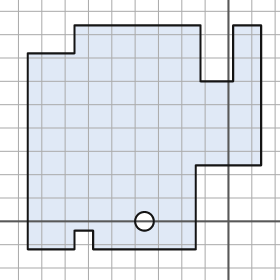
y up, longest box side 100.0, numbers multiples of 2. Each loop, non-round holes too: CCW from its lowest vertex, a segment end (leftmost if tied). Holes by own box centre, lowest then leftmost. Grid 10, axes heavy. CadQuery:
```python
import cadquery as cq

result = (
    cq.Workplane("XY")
    .moveTo(-86.0, -12.0)
    .lineTo(-66.0, -12.0)
    .lineTo(-66.0, -4.0)
    .lineTo(-58.0, -4.0)
    .lineTo(-58.0, -12.0)
    .lineTo(-14.0, -12.0)
    .lineTo(-14.0, 24.0)
    .lineTo(14.0, 24.0)
    .lineTo(14.0, 84.0)
    .lineTo(2.0, 84.0)
    .lineTo(2.0, 60.0)
    .lineTo(-12.0, 60.0)
    .lineTo(-12.0, 84.0)
    .lineTo(-66.0, 84.0)
    .lineTo(-66.0, 72.0)
    .lineTo(-86.0, 72.0)
    .close()
    .moveTo(-36.0, 0.0)
    .circle(4.0)
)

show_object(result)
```